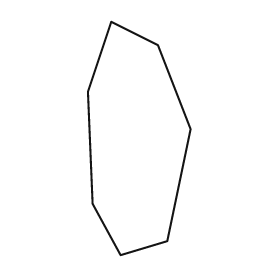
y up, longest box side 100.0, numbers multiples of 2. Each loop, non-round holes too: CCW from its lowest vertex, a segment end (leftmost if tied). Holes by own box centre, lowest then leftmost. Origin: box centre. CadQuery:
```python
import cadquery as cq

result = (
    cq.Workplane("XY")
    .moveTo(-8.0, -50.0)
    .lineTo(12.0, -44.0)
    .lineTo(22.0, 4.0)
    .lineTo(8.0, 40.0)
    .lineTo(-12.0, 50.0)
    .lineTo(-22.0, 20.0)
    .lineTo(-20.0, -28.0)
    .close()
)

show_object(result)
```